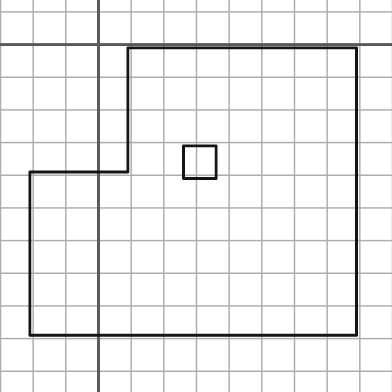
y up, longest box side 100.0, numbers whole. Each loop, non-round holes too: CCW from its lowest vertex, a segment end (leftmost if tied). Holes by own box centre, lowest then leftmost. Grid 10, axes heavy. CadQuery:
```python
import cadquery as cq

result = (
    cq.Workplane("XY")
    .moveTo(-21.0, -89.0)
    .lineTo(79.0, -89.0)
    .lineTo(79.0, -1.0)
    .lineTo(9.0, -1.0)
    .lineTo(9.0, -39.0)
    .lineTo(-21.0, -39.0)
    .close()
    .moveTo(26.0, -41.0)
    .lineTo(36.0, -41.0)
    .lineTo(36.0, -31.0)
    .lineTo(26.0, -31.0)
    .close()
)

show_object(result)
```